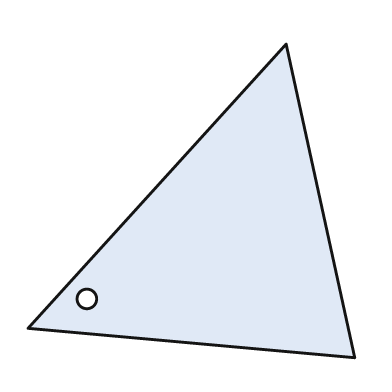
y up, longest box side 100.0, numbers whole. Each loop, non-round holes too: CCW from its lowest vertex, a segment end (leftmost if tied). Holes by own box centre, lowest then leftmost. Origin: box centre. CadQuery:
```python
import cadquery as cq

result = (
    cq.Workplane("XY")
    .moveTo(50.0, -48.0)
    .lineTo(29.0, 48.0)
    .lineTo(-50.0, -39.0)
    .close()
    .moveTo(-32.0, -30.0)
    .circle(3.0)
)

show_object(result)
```